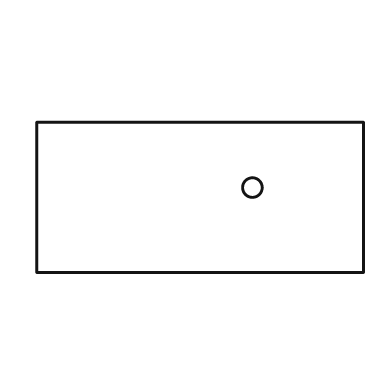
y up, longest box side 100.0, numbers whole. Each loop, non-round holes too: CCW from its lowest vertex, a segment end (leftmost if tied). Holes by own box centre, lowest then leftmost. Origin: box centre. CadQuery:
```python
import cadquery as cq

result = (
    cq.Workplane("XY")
    .moveTo(-50.0, -23.0)
    .lineTo(50.0, -23.0)
    .lineTo(50.0, 23.0)
    .lineTo(-50.0, 23.0)
    .close()
    .moveTo(16.0, 3.0)
    .circle(3.0)
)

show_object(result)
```